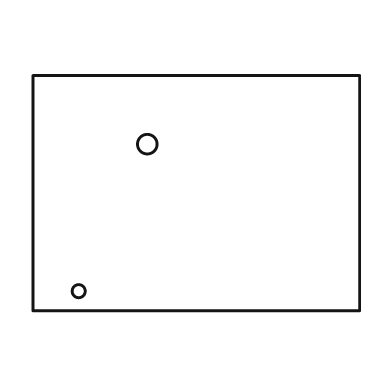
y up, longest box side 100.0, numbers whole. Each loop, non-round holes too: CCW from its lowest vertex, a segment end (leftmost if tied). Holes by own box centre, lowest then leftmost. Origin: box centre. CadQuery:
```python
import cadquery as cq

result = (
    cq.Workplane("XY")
    .moveTo(-50.0, -36.0)
    .lineTo(50.0, -36.0)
    .lineTo(50.0, 36.0)
    .lineTo(-50.0, 36.0)
    .close()
    .moveTo(-36.0, -30.0)
    .circle(2.0)
    .moveTo(-15.0, 15.0)
    .circle(3.0)
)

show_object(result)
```